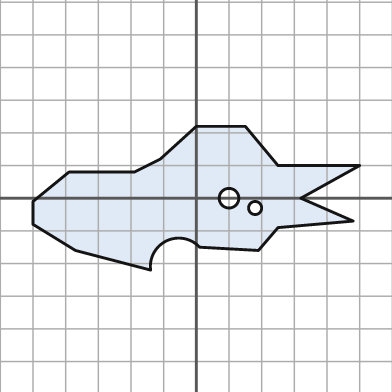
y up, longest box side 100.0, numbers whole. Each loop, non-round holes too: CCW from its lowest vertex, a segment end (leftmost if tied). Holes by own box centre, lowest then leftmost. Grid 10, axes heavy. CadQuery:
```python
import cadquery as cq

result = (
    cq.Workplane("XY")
    .moveTo(-14.0, -22.0)
    .threePointArc((-9.0, -13.0), (1.0, -15.0))
    .lineTo(19.0, -16.0)
    .lineTo(25.0, -9.0)
    .lineTo(48.0, -7.0)
    .lineTo(32.0, 0.0)
    .lineTo(50.0, 10.0)
    .lineTo(25.0, 10.0)
    .lineTo(15.0, 22.0)
    .lineTo(0.0, 22.0)
    .lineTo(-11.0, 12.0)
    .lineTo(-19.0, 8.0)
    .lineTo(-39.0, 8.0)
    .lineTo(-50.0, -1.0)
    .lineTo(-50.0, -8.0)
    .lineTo(-37.0, -16.0)
    .close()
    .moveTo(18.0, -3.0)
    .circle(2.0)
    .moveTo(10.0, 0.0)
    .circle(3.0)
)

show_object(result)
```